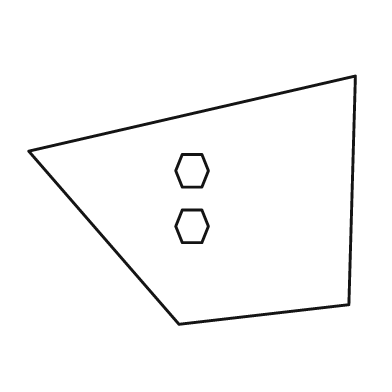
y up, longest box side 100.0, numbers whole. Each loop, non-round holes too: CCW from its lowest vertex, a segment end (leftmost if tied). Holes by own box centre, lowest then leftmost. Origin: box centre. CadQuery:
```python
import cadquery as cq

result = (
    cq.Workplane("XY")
    .moveTo(-4.0, -38.0)
    .lineTo(48.0, -32.0)
    .lineTo(50.0, 38.0)
    .lineTo(-50.0, 15.0)
    .close()
    .moveTo(-3.0, -13.0)
    .lineTo(3.0, -13.0)
    .lineTo(5.0, -8.0)
    .lineTo(3.0, -3.0)
    .lineTo(-3.0, -3.0)
    .lineTo(-5.0, -8.0)
    .close()
    .moveTo(-3.0, 4.0)
    .lineTo(3.0, 4.0)
    .lineTo(5.0, 9.0)
    .lineTo(3.0, 14.0)
    .lineTo(-3.0, 14.0)
    .lineTo(-5.0, 9.0)
    .close()
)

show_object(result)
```